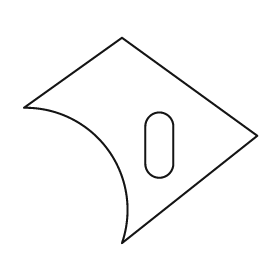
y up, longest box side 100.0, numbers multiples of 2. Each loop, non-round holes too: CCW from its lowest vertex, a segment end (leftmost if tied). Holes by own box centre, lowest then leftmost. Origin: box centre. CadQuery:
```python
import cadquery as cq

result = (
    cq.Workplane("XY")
    .moveTo(-8.0, -44.0)
    .lineTo(50.0, 2.0)
    .lineTo(-8.0, 44.0)
    .lineTo(-50.0, 14.0)
    .threePointArc((-14.0, -4.0), (-8.0, -44.0))
    .close()
    .moveTo(2.0, -10.0)
    .threePointArc((8.0, -16.0), (14.0, -10.0))
    .lineTo(14.0, 6.0)
    .threePointArc((8.0, 12.0), (2.0, 6.0))
    .close()
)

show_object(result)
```